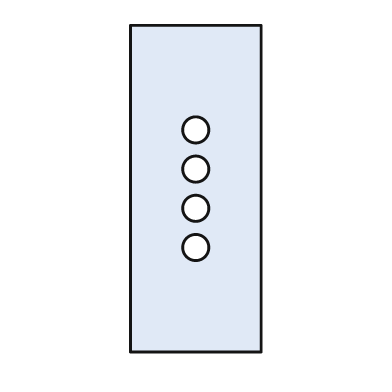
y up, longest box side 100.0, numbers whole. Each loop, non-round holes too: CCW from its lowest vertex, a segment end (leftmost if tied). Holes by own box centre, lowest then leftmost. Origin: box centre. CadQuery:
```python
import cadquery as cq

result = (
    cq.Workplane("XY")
    .moveTo(-20.0, -50.0)
    .lineTo(20.0, -50.0)
    .lineTo(20.0, 50.0)
    .lineTo(-20.0, 50.0)
    .close()
    .moveTo(0.0, -18.0)
    .circle(4.0)
    .moveTo(0.0, -6.0)
    .circle(4.0)
    .moveTo(0.0, 6.0)
    .circle(4.0)
    .moveTo(0.0, 18.0)
    .circle(4.0)
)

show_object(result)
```